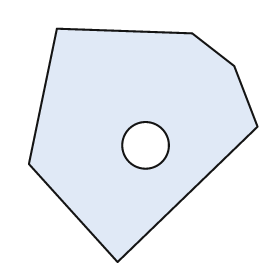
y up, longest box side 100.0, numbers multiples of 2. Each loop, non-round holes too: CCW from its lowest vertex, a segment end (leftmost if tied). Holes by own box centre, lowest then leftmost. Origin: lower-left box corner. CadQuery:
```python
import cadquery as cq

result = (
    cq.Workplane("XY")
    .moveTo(38.0, 0.0)
    .lineTo(98.0, 58.0)
    .lineTo(88.0, 84.0)
    .lineTo(70.0, 98.0)
    .lineTo(12.0, 100.0)
    .lineTo(0.0, 42.0)
    .close()
    .moveTo(50.0, 50.0)
    .circle(10.0)
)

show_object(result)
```